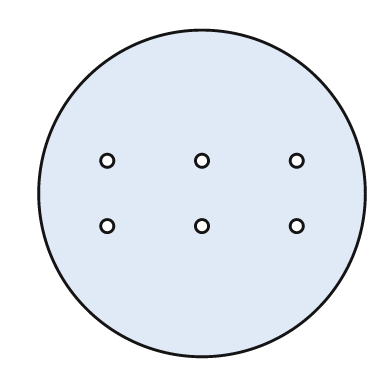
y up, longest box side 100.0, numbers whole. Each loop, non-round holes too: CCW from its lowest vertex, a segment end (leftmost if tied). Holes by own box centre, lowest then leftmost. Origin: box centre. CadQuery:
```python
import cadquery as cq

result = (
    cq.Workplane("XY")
    .moveTo(0.0, 0.0)
    .circle(50.0)
    .moveTo(-29.0, -10.0)
    .circle(2.0)
    .moveTo(0.0, -10.0)
    .circle(2.0)
    .moveTo(29.0, -10.0)
    .circle(2.0)
    .moveTo(-29.0, 10.0)
    .circle(2.0)
    .moveTo(0.0, 10.0)
    .circle(2.0)
    .moveTo(29.0, 10.0)
    .circle(2.0)
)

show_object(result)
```